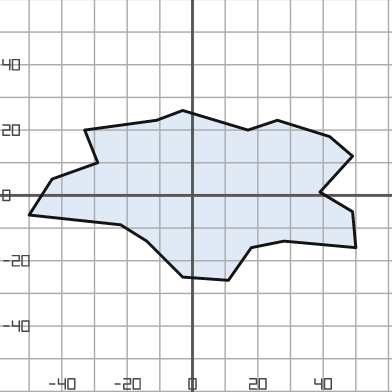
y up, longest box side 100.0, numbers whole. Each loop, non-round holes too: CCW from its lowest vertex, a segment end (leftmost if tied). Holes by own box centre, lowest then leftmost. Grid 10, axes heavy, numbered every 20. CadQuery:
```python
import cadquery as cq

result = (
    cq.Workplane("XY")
    .moveTo(11.0, -26.0)
    .lineTo(18.0, -16.0)
    .lineTo(28.0, -14.0)
    .lineTo(50.0, -16.0)
    .lineTo(49.0, -5.0)
    .lineTo(39.0, 1.0)
    .lineTo(49.0, 12.0)
    .lineTo(42.0, 18.0)
    .lineTo(26.0, 23.0)
    .lineTo(17.0, 20.0)
    .lineTo(-3.0, 26.0)
    .lineTo(-11.0, 23.0)
    .lineTo(-33.0, 20.0)
    .lineTo(-29.0, 10.0)
    .lineTo(-43.0, 5.0)
    .lineTo(-50.0, -6.0)
    .lineTo(-22.0, -9.0)
    .lineTo(-14.0, -14.0)
    .lineTo(-3.0, -25.0)
    .close()
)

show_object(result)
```